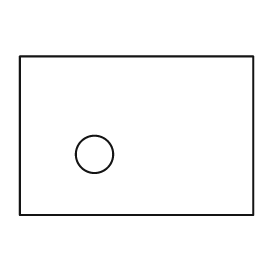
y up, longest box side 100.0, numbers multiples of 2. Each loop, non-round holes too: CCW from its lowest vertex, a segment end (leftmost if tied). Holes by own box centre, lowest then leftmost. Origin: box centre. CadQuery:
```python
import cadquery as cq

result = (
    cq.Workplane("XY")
    .moveTo(-50.0, -34.0)
    .lineTo(50.0, -34.0)
    .lineTo(50.0, 34.0)
    .lineTo(-50.0, 34.0)
    .close()
    .moveTo(-18.0, -8.0)
    .circle(8.0)
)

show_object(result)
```